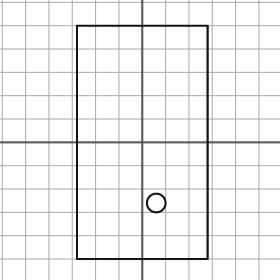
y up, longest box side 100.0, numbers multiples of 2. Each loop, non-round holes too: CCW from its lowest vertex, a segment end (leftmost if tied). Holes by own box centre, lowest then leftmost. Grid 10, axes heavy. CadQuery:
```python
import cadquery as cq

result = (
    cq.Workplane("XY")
    .moveTo(-28.0, -50.0)
    .lineTo(28.0, -50.0)
    .lineTo(28.0, 50.0)
    .lineTo(-28.0, 50.0)
    .close()
    .moveTo(6.0, -26.0)
    .circle(4.0)
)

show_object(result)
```